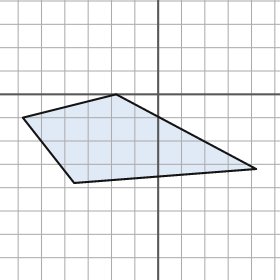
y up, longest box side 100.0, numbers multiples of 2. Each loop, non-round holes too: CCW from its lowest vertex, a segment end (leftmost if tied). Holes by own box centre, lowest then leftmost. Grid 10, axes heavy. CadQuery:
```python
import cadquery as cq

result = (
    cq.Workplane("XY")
    .moveTo(-36.0, -38.0)
    .lineTo(42.0, -32.0)
    .lineTo(-18.0, 0.0)
    .lineTo(-58.0, -10.0)
    .close()
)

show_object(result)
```